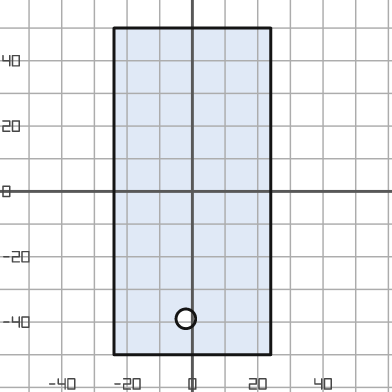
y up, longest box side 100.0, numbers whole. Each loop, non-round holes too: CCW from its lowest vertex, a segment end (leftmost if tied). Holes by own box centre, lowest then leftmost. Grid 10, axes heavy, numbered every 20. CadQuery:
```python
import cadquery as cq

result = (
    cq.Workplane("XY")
    .moveTo(-24.0, -50.0)
    .lineTo(24.0, -50.0)
    .lineTo(24.0, 50.0)
    .lineTo(-24.0, 50.0)
    .close()
    .moveTo(-2.0, -39.0)
    .circle(3.0)
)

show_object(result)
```